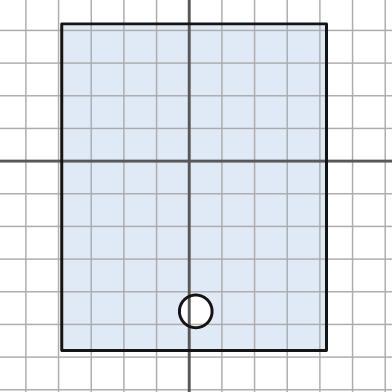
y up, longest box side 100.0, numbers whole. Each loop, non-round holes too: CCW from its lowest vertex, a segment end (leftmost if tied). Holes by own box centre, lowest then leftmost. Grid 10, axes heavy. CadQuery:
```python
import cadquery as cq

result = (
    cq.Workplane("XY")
    .moveTo(-39.0, -58.0)
    .lineTo(42.0, -58.0)
    .lineTo(42.0, 42.0)
    .lineTo(-39.0, 42.0)
    .close()
    .moveTo(2.0, -46.0)
    .circle(5.0)
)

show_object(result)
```